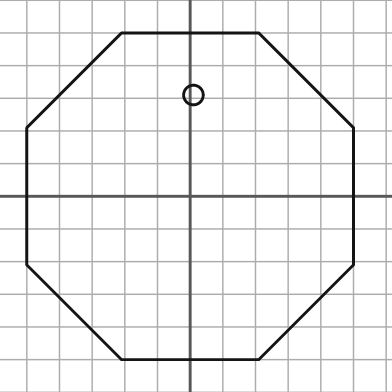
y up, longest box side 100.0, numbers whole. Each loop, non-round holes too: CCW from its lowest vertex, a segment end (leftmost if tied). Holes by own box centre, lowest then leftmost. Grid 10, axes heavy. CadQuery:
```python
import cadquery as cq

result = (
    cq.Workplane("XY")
    .moveTo(-21.0, -50.0)
    .lineTo(21.0, -50.0)
    .lineTo(50.0, -21.0)
    .lineTo(50.0, 21.0)
    .lineTo(21.0, 50.0)
    .lineTo(-21.0, 50.0)
    .lineTo(-50.0, 21.0)
    .lineTo(-50.0, -21.0)
    .close()
    .moveTo(1.0, 31.0)
    .circle(3.0)
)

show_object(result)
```